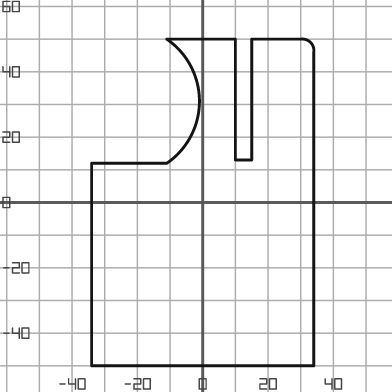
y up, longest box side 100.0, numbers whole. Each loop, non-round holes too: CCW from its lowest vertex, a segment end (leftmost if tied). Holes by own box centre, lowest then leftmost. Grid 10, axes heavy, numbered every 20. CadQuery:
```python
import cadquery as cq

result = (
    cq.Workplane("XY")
    .moveTo(-34.0, -50.0)
    .lineTo(34.0, -50.0)
    .lineTo(34.0, 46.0)
    .threePointArc((33.0, 49.0), (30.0, 50.0))
    .lineTo(15.0, 50.0)
    .lineTo(15.0, 13.0)
    .lineTo(10.0, 13.0)
    .lineTo(10.0, 50.0)
    .lineTo(-11.0, 50.0)
    .threePointArc((-1.0, 31.0), (-11.0, 12.0))
    .lineTo(-34.0, 12.0)
    .close()
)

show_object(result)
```